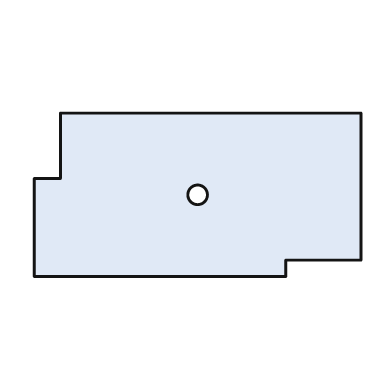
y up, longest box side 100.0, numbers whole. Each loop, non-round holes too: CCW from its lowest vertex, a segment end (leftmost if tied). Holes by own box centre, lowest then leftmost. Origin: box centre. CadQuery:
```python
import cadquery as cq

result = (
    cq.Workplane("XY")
    .moveTo(-50.0, -25.0)
    .lineTo(27.0, -25.0)
    .lineTo(27.0, -20.0)
    .lineTo(50.0, -20.0)
    .lineTo(50.0, 25.0)
    .lineTo(-42.0, 25.0)
    .lineTo(-42.0, 5.0)
    .lineTo(-50.0, 5.0)
    .close()
    .moveTo(0.0, 0.0)
    .circle(3.0)
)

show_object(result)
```